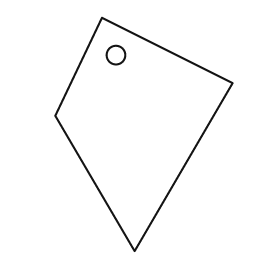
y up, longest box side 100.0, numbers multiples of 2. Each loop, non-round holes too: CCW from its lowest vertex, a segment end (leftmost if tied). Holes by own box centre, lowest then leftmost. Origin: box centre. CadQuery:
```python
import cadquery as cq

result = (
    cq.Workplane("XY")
    .moveTo(-4.0, -50.0)
    .lineTo(38.0, 22.0)
    .lineTo(-18.0, 50.0)
    .lineTo(-38.0, 8.0)
    .close()
    .moveTo(-12.0, 34.0)
    .circle(4.0)
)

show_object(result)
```